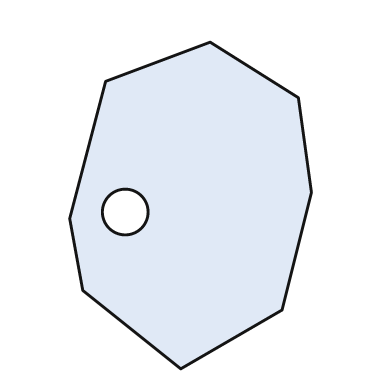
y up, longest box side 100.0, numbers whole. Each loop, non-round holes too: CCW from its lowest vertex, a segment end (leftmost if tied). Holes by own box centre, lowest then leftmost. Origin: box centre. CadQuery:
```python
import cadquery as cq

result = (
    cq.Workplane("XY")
    .moveTo(-3.0, -50.0)
    .lineTo(28.0, -32.0)
    .lineTo(37.0, 4.0)
    .lineTo(33.0, 33.0)
    .lineTo(6.0, 50.0)
    .lineTo(-26.0, 38.0)
    .lineTo(-37.0, -4.0)
    .lineTo(-33.0, -26.0)
    .close()
    .moveTo(-20.0, -2.0)
    .circle(7.0)
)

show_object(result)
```